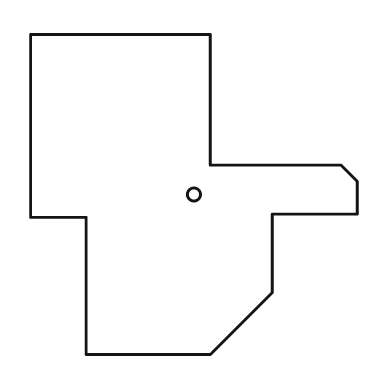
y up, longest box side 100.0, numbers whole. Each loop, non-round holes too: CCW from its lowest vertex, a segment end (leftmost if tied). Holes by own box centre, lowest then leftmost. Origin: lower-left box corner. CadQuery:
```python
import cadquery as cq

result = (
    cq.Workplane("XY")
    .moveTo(17.0, 0.0)
    .lineTo(55.0, 0.0)
    .lineTo(74.0, 19.0)
    .lineTo(74.0, 43.0)
    .lineTo(100.0, 43.0)
    .lineTo(100.0, 53.0)
    .lineTo(95.0, 58.0)
    .lineTo(55.0, 58.0)
    .lineTo(55.0, 98.0)
    .lineTo(0.0, 98.0)
    .lineTo(0.0, 42.0)
    .lineTo(17.0, 42.0)
    .close()
    .moveTo(50.0, 49.0)
    .circle(2.0)
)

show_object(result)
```